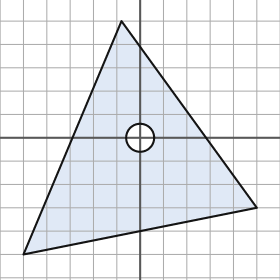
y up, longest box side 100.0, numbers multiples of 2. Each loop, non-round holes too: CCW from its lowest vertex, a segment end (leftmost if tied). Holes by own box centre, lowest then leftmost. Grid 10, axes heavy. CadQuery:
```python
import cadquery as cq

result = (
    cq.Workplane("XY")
    .moveTo(-50.0, -50.0)
    .lineTo(50.0, -30.0)
    .lineTo(-8.0, 50.0)
    .close()
    .moveTo(0.0, 0.0)
    .circle(6.0)
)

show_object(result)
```